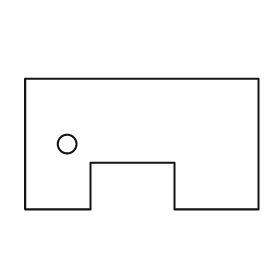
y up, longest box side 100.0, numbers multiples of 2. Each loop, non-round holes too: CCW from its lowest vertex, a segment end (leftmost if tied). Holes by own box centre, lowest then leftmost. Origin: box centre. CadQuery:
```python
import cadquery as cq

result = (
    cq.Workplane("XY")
    .moveTo(-50.0, -28.0)
    .lineTo(-22.0, -28.0)
    .lineTo(-22.0, -8.0)
    .lineTo(14.0, -8.0)
    .lineTo(14.0, -28.0)
    .lineTo(50.0, -28.0)
    .lineTo(50.0, 28.0)
    .lineTo(-50.0, 28.0)
    .close()
    .moveTo(-32.0, 0.0)
    .circle(4.0)
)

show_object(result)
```